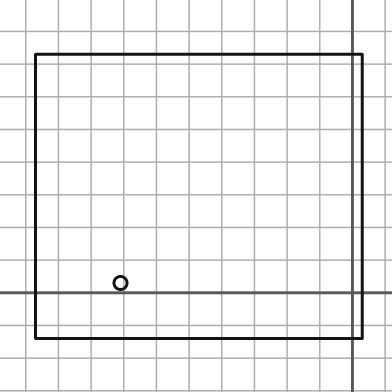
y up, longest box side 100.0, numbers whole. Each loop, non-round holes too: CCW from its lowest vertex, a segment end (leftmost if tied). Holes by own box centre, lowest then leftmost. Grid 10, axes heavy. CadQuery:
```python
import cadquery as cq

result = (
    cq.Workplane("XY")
    .moveTo(-97.0, -14.0)
    .lineTo(3.0, -14.0)
    .lineTo(3.0, 73.0)
    .lineTo(-97.0, 73.0)
    .close()
    .moveTo(-71.0, 3.0)
    .circle(2.0)
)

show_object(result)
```